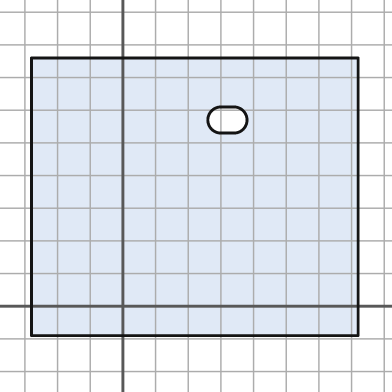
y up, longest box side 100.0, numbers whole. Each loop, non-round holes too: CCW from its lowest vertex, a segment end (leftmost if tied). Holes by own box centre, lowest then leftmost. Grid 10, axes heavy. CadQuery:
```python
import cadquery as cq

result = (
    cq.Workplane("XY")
    .moveTo(-28.0, -9.0)
    .lineTo(72.0, -9.0)
    .lineTo(72.0, 76.0)
    .lineTo(-28.0, 76.0)
    .close()
    .moveTo(30.0, 53.0)
    .lineTo(34.0, 53.0)
    .threePointArc((38.0, 57.0), (34.0, 61.0))
    .lineTo(30.0, 61.0)
    .threePointArc((26.0, 57.0), (30.0, 53.0))
    .close()
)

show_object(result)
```